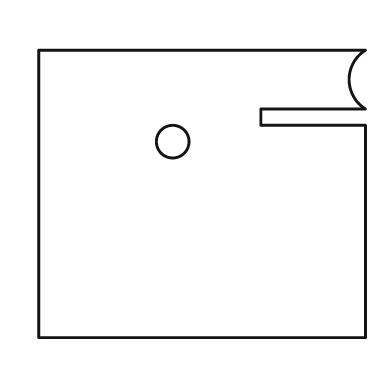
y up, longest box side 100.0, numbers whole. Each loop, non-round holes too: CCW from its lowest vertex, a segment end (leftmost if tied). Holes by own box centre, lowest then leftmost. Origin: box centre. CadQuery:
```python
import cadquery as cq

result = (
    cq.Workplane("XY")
    .moveTo(-50.0, -44.0)
    .lineTo(50.0, -44.0)
    .lineTo(50.0, 21.0)
    .lineTo(18.0, 21.0)
    .lineTo(18.0, 26.0)
    .lineTo(50.0, 26.0)
    .threePointArc((45.0, 35.0), (50.0, 44.0))
    .lineTo(-50.0, 44.0)
    .close()
    .moveTo(-9.0, 16.0)
    .circle(5.0)
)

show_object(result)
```